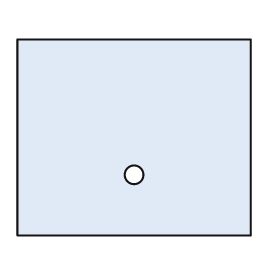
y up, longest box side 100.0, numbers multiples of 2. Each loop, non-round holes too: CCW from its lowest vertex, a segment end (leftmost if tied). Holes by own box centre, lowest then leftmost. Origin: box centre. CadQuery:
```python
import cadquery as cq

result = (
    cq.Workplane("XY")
    .moveTo(-50.0, -42.0)
    .lineTo(50.0, -42.0)
    .lineTo(50.0, 42.0)
    .lineTo(-50.0, 42.0)
    .close()
    .moveTo(0.0, -16.0)
    .circle(4.0)
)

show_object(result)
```